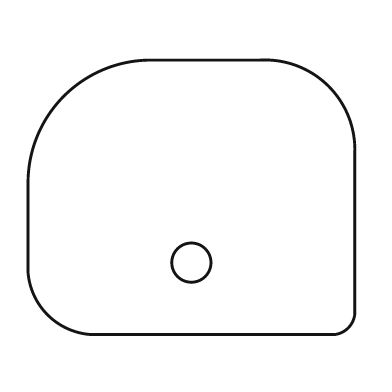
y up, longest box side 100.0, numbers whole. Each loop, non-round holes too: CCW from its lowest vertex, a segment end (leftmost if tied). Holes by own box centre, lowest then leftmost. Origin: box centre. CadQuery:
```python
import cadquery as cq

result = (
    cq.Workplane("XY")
    .moveTo(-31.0, -42.0)
    .lineTo(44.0, -42.0)
    .threePointArc((48.0, -40.0), (50.0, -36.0))
    .lineTo(50.0, 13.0)
    .threePointArc((42.0, 34.0), (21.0, 42.0))
    .lineTo(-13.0, 42.0)
    .threePointArc((-39.0, 31.0), (-50.0, 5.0))
    .lineTo(-50.0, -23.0)
    .threePointArc((-44.0, -36.0), (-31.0, -42.0))
    .close()
    .moveTo(0.0, -20.0)
    .circle(6.0)
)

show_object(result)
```